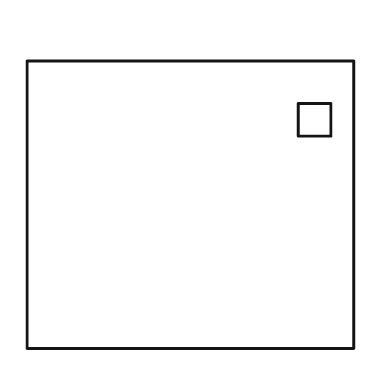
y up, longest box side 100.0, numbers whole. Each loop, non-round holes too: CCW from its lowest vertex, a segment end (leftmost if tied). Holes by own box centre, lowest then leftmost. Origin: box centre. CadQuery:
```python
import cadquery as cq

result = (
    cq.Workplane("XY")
    .moveTo(-50.0, -44.0)
    .lineTo(50.0, -44.0)
    .lineTo(50.0, 44.0)
    .lineTo(-50.0, 44.0)
    .close()
    .moveTo(33.0, 21.0)
    .lineTo(43.0, 21.0)
    .lineTo(43.0, 31.0)
    .lineTo(33.0, 31.0)
    .close()
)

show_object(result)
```